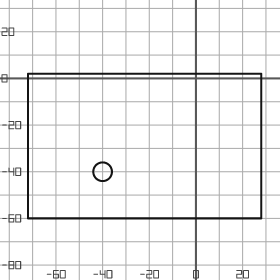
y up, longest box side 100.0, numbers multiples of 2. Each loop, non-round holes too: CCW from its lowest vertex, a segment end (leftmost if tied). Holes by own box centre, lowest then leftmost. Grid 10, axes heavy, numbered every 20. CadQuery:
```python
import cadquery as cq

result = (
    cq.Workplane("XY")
    .moveTo(-72.0, -60.0)
    .lineTo(28.0, -60.0)
    .lineTo(28.0, 2.0)
    .lineTo(-72.0, 2.0)
    .close()
    .moveTo(-40.0, -40.0)
    .circle(4.0)
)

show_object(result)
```